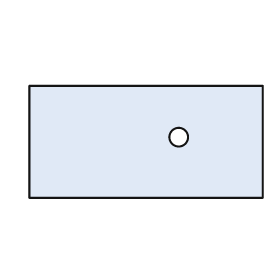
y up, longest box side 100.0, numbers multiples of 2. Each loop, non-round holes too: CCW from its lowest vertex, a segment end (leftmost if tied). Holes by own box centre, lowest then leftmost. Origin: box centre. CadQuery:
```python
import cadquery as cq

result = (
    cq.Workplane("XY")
    .moveTo(-50.0, -24.0)
    .lineTo(50.0, -24.0)
    .lineTo(50.0, 24.0)
    .lineTo(-50.0, 24.0)
    .close()
    .moveTo(14.0, 2.0)
    .circle(4.0)
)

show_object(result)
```